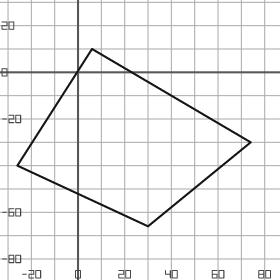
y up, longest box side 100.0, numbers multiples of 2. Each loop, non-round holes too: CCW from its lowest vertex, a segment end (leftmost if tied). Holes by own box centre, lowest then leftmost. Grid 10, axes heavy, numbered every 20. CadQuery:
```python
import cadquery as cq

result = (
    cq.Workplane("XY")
    .moveTo(30.0, -66.0)
    .lineTo(74.0, -30.0)
    .lineTo(6.0, 10.0)
    .lineTo(-26.0, -40.0)
    .close()
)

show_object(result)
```